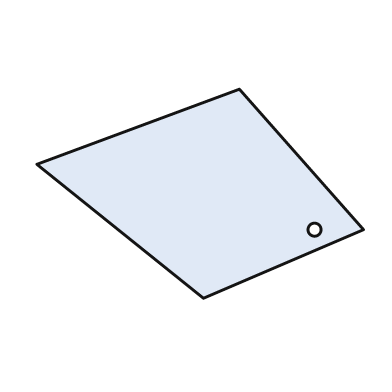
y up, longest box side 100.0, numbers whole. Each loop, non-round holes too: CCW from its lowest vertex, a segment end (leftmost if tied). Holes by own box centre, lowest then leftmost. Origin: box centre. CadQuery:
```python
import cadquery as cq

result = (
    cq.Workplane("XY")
    .moveTo(1.0, -32.0)
    .lineTo(50.0, -11.0)
    .lineTo(12.0, 32.0)
    .lineTo(-50.0, 9.0)
    .close()
    .moveTo(35.0, -11.0)
    .circle(2.0)
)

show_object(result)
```